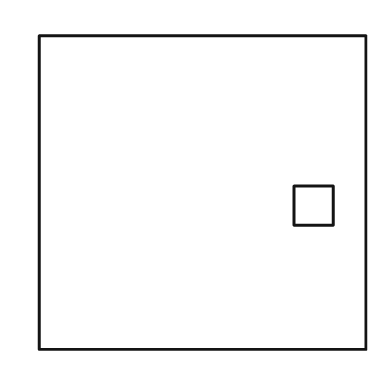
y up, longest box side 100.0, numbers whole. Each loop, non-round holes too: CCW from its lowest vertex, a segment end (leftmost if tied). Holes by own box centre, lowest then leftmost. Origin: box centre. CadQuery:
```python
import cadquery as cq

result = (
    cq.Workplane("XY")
    .moveTo(-50.0, -48.0)
    .lineTo(50.0, -48.0)
    .lineTo(50.0, 48.0)
    .lineTo(-50.0, 48.0)
    .close()
    .moveTo(28.0, -10.0)
    .lineTo(40.0, -10.0)
    .lineTo(40.0, 2.0)
    .lineTo(28.0, 2.0)
    .close()
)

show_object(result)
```